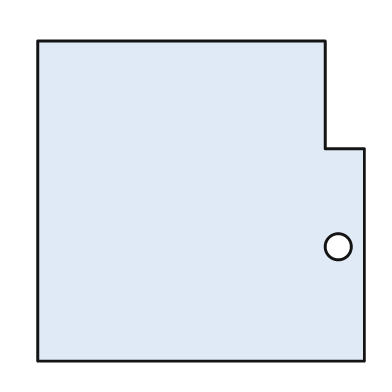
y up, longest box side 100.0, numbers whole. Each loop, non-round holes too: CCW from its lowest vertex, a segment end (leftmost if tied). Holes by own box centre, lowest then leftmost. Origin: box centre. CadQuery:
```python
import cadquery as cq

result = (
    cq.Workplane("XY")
    .moveTo(-50.0, -49.0)
    .lineTo(50.0, -49.0)
    .lineTo(50.0, 16.0)
    .lineTo(38.0, 16.0)
    .lineTo(38.0, 49.0)
    .lineTo(-50.0, 49.0)
    .close()
    .moveTo(42.0, -14.0)
    .circle(4.0)
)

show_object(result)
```